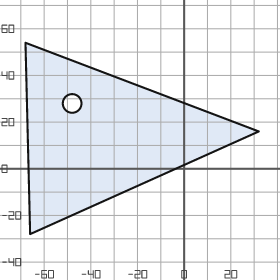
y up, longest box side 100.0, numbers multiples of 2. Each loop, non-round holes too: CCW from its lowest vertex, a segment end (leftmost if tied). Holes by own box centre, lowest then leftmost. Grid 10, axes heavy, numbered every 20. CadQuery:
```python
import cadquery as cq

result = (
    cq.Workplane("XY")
    .moveTo(-66.0, -28.0)
    .lineTo(32.0, 16.0)
    .lineTo(-68.0, 54.0)
    .close()
    .moveTo(-48.0, 28.0)
    .circle(4.0)
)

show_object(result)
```